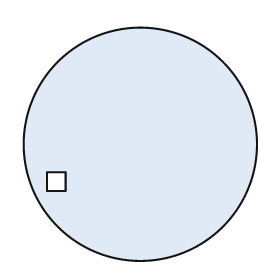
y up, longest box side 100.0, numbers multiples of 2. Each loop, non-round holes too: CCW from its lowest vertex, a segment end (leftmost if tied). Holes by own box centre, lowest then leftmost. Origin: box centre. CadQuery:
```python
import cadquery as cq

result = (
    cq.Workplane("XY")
    .moveTo(0.0, 0.0)
    .circle(50.0)
    .moveTo(-40.0, -20.0)
    .lineTo(-32.0, -20.0)
    .lineTo(-32.0, -12.0)
    .lineTo(-40.0, -12.0)
    .close()
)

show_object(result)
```